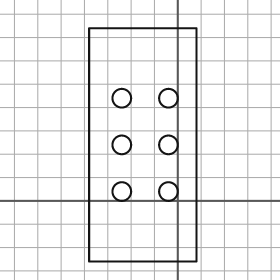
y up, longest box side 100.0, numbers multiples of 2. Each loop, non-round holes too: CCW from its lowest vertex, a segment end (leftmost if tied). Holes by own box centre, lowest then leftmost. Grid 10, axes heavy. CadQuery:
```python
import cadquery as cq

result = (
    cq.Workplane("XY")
    .moveTo(-38.0, -26.0)
    .lineTo(8.0, -26.0)
    .lineTo(8.0, 74.0)
    .lineTo(-38.0, 74.0)
    .close()
    .moveTo(-24.0, 4.0)
    .circle(4.0)
    .moveTo(-4.0, 4.0)
    .circle(4.0)
    .moveTo(-24.0, 24.0)
    .circle(4.0)
    .moveTo(-4.0, 24.0)
    .circle(4.0)
    .moveTo(-24.0, 44.0)
    .circle(4.0)
    .moveTo(-4.0, 44.0)
    .circle(4.0)
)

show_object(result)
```